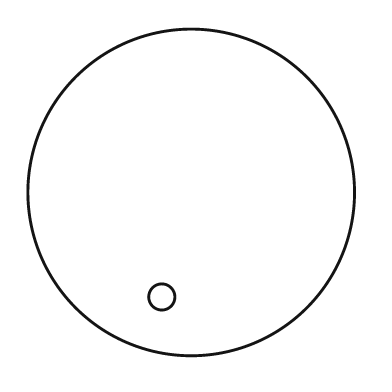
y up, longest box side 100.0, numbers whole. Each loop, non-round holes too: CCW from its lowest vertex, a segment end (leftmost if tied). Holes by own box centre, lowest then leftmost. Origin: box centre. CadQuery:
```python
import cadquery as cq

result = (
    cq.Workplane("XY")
    .moveTo(0.0, 0.0)
    .circle(50.0)
    .moveTo(-9.0, -32.0)
    .circle(4.0)
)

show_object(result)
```